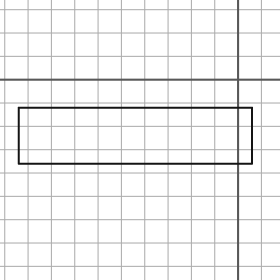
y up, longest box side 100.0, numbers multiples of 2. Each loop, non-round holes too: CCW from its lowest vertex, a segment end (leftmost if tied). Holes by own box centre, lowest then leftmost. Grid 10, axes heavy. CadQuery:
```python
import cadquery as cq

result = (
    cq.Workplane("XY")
    .moveTo(-94.0, -36.0)
    .lineTo(6.0, -36.0)
    .lineTo(6.0, -12.0)
    .lineTo(-94.0, -12.0)
    .close()
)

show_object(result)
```